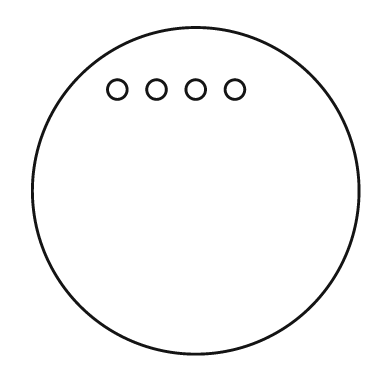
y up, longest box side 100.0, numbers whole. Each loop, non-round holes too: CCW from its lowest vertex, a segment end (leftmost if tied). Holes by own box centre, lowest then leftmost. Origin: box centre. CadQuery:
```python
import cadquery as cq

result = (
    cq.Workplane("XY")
    .moveTo(0.0, 0.0)
    .circle(50.0)
    .moveTo(-24.0, 31.0)
    .circle(3.0)
    .moveTo(-12.0, 31.0)
    .circle(3.0)
    .moveTo(0.0, 31.0)
    .circle(3.0)
    .moveTo(12.0, 31.0)
    .circle(3.0)
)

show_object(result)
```